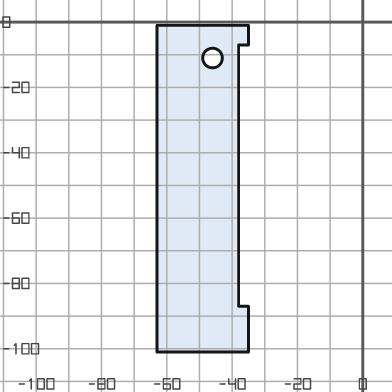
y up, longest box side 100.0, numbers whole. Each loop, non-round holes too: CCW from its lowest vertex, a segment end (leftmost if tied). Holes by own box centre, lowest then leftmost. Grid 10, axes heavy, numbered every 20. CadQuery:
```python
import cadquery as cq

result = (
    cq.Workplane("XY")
    .moveTo(-63.0, -101.0)
    .lineTo(-35.0, -101.0)
    .lineTo(-35.0, -87.0)
    .lineTo(-38.0, -87.0)
    .lineTo(-38.0, -7.0)
    .lineTo(-35.0, -7.0)
    .lineTo(-35.0, -1.0)
    .lineTo(-63.0, -1.0)
    .close()
    .moveTo(-46.0, -11.0)
    .circle(3.0)
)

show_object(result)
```